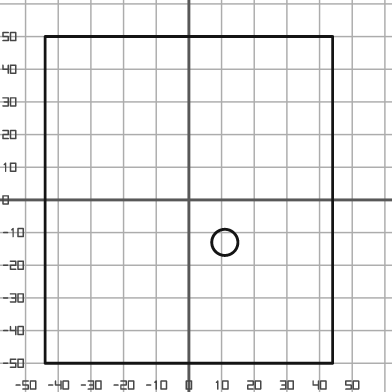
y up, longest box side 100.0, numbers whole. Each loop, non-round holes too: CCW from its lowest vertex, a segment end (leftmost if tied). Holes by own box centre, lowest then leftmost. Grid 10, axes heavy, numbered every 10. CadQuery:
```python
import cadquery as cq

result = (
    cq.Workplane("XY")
    .moveTo(-44.0, -50.0)
    .lineTo(44.0, -50.0)
    .lineTo(44.0, 50.0)
    .lineTo(-44.0, 50.0)
    .close()
    .moveTo(11.0, -13.0)
    .circle(4.0)
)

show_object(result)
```